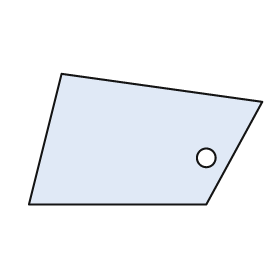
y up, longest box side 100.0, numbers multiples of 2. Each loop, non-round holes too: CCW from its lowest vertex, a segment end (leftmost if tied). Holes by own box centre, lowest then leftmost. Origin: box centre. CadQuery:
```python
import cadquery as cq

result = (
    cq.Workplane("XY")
    .moveTo(-50.0, -28.0)
    .lineTo(26.0, -28.0)
    .lineTo(50.0, 16.0)
    .lineTo(-36.0, 28.0)
    .close()
    .moveTo(26.0, -8.0)
    .circle(4.0)
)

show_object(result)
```